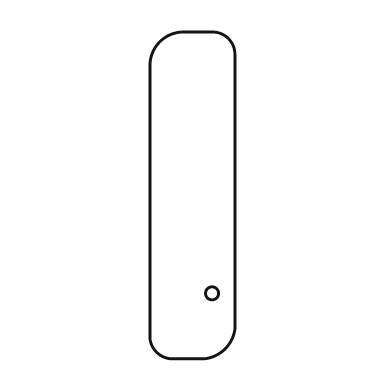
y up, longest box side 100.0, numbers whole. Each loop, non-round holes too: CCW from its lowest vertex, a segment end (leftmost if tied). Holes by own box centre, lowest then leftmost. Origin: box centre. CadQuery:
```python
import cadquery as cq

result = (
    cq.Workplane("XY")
    .moveTo(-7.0, -50.0)
    .lineTo(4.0, -50.0)
    .threePointArc((10.0, -47.0), (13.0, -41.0))
    .lineTo(13.0, 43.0)
    .threePointArc((11.0, 48.0), (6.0, 50.0))
    .lineTo(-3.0, 50.0)
    .threePointArc((-10.0, 47.0), (-13.0, 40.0))
    .lineTo(-13.0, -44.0)
    .threePointArc((-11.0, -48.0), (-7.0, -50.0))
    .close()
    .moveTo(6.0, -30.0)
    .circle(2.0)
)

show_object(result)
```